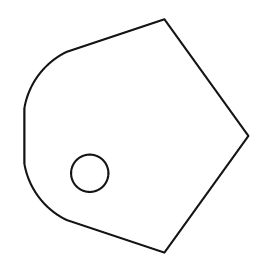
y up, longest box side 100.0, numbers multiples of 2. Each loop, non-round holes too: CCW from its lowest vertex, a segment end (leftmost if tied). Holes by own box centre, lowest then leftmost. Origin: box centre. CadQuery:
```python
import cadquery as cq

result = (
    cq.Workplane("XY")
    .moveTo(12.0, -50.0)
    .lineTo(48.0, 0.0)
    .lineTo(12.0, 50.0)
    .lineTo(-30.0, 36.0)
    .threePointArc((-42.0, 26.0), (-48.0, 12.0))
    .lineTo(-48.0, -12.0)
    .threePointArc((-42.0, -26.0), (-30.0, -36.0))
    .close()
    .moveTo(-20.0, -16.0)
    .circle(8.0)
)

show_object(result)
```